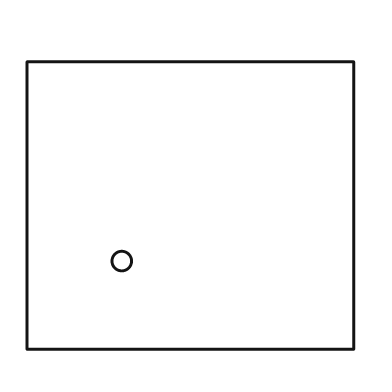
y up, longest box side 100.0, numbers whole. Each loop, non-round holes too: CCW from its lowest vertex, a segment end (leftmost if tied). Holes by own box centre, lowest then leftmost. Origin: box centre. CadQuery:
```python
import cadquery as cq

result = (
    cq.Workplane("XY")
    .moveTo(-50.0, -44.0)
    .lineTo(50.0, -44.0)
    .lineTo(50.0, 44.0)
    .lineTo(-50.0, 44.0)
    .close()
    .moveTo(-21.0, -17.0)
    .circle(3.0)
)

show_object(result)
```